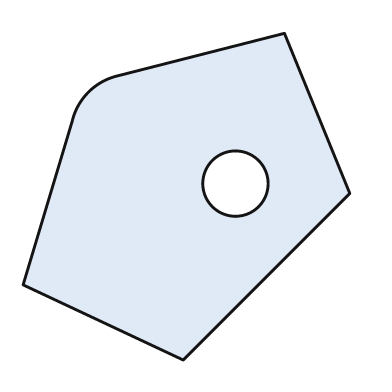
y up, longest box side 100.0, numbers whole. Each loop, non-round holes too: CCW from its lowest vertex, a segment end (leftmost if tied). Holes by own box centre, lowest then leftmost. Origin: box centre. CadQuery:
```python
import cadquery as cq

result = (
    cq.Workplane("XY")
    .moveTo(-1.0, -50.0)
    .lineTo(50.0, 1.0)
    .lineTo(30.0, 50.0)
    .lineTo(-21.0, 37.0)
    .threePointArc((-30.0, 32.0), (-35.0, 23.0))
    .lineTo(-50.0, -27.0)
    .close()
    .moveTo(15.0, 4.0)
    .circle(10.0)
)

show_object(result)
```